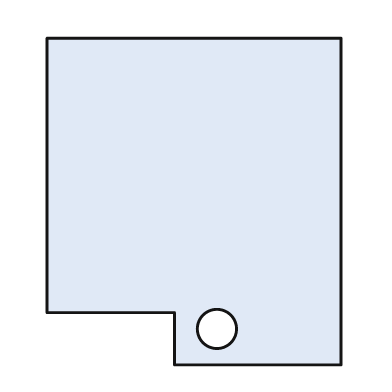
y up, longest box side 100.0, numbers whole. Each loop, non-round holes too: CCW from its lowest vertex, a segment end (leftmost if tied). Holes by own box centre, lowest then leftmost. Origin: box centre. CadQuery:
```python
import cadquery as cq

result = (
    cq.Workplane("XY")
    .moveTo(-6.0, -50.0)
    .lineTo(45.0, -50.0)
    .lineTo(45.0, 50.0)
    .lineTo(-45.0, 50.0)
    .lineTo(-45.0, -34.0)
    .lineTo(-6.0, -34.0)
    .close()
    .moveTo(7.0, -39.0)
    .circle(6.0)
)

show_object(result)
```